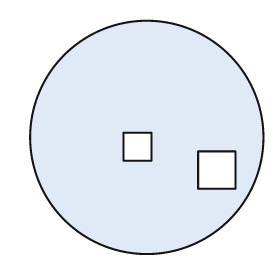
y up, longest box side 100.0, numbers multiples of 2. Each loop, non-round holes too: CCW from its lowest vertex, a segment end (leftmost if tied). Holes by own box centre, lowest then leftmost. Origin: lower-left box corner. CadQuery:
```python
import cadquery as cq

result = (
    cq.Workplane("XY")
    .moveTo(50.0, 50.0)
    .circle(50.0)
    .moveTo(72.0, 28.0)
    .lineTo(88.0, 28.0)
    .lineTo(88.0, 44.0)
    .lineTo(72.0, 44.0)
    .close()
    .moveTo(40.0, 40.0)
    .lineTo(52.0, 40.0)
    .lineTo(52.0, 52.0)
    .lineTo(40.0, 52.0)
    .close()
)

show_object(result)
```